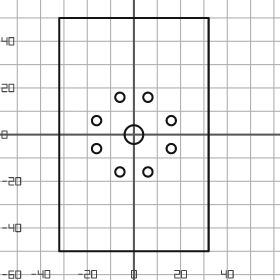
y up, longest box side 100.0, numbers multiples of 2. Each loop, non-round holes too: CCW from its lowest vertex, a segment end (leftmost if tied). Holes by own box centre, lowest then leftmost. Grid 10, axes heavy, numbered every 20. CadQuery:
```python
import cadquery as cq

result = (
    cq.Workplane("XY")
    .moveTo(-32.0, -50.0)
    .lineTo(32.0, -50.0)
    .lineTo(32.0, 50.0)
    .lineTo(-32.0, 50.0)
    .close()
    .moveTo(-6.0, -16.0)
    .circle(2.0)
    .moveTo(6.0, -16.0)
    .circle(2.0)
    .moveTo(-16.0, -6.0)
    .circle(2.0)
    .moveTo(16.0, -6.0)
    .circle(2.0)
    .moveTo(0.0, 0.0)
    .circle(4.0)
    .moveTo(-16.0, 6.0)
    .circle(2.0)
    .moveTo(16.0, 6.0)
    .circle(2.0)
    .moveTo(-6.0, 16.0)
    .circle(2.0)
    .moveTo(6.0, 16.0)
    .circle(2.0)
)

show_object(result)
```